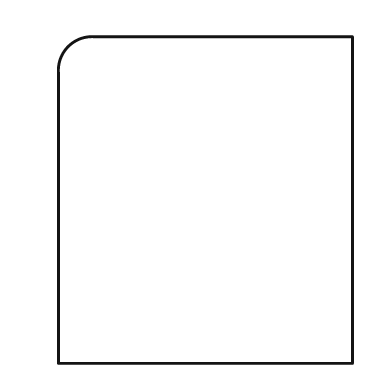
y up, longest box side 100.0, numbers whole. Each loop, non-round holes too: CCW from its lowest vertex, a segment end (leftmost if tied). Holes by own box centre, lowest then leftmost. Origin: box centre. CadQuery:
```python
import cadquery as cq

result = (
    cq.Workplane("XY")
    .moveTo(-45.0, -50.0)
    .lineTo(45.0, -50.0)
    .lineTo(45.0, 50.0)
    .lineTo(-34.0, 50.0)
    .threePointArc((-42.0, 47.0), (-45.0, 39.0))
    .close()
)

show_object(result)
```